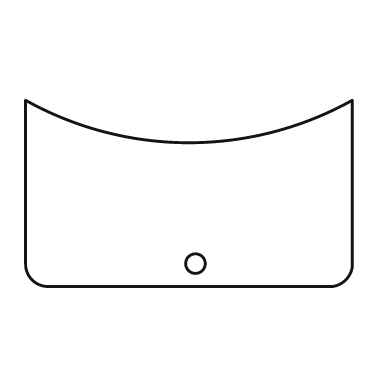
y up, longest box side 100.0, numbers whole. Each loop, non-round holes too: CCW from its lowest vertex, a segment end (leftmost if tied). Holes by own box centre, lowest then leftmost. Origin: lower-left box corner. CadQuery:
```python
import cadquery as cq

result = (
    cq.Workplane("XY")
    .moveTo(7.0, 0.0)
    .lineTo(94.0, 0.0)
    .threePointArc((98.0, 2.0), (100.0, 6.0))
    .lineTo(100.0, 57.0)
    .threePointArc((50.0, 44.0), (0.0, 57.0))
    .lineTo(0.0, 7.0)
    .threePointArc((2.0, 2.0), (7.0, 0.0))
    .close()
    .moveTo(52.0, 7.0)
    .circle(3.0)
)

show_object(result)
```